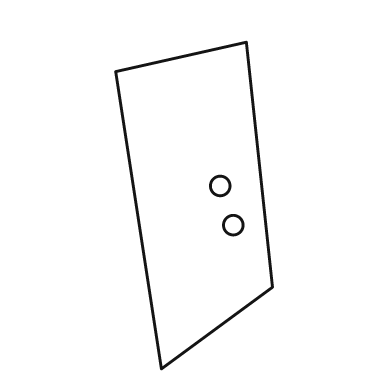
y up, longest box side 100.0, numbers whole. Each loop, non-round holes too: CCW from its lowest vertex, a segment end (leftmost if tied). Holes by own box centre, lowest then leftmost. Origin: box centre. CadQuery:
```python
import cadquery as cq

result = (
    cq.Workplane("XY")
    .moveTo(-10.0, -50.0)
    .lineTo(24.0, -25.0)
    .lineTo(16.0, 50.0)
    .lineTo(-24.0, 41.0)
    .close()
    .moveTo(12.0, -6.0)
    .circle(3.0)
    .moveTo(8.0, 6.0)
    .circle(3.0)
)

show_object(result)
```